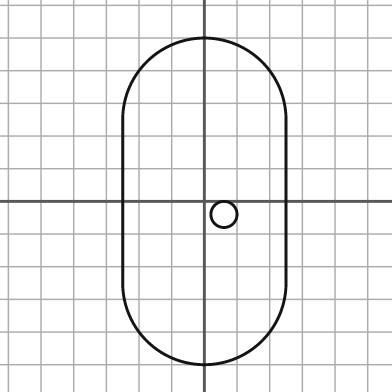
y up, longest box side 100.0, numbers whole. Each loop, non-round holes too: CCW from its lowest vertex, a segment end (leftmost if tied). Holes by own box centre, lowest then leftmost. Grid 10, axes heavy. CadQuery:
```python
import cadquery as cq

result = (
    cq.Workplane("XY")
    .moveTo(-25.0, -25.0)
    .threePointArc((0.0, -50.0), (25.0, -25.0))
    .lineTo(25.0, 25.0)
    .threePointArc((0.0, 50.0), (-25.0, 25.0))
    .close()
    .moveTo(6.0, -4.0)
    .circle(4.0)
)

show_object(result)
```